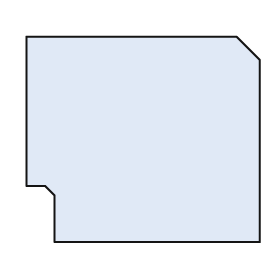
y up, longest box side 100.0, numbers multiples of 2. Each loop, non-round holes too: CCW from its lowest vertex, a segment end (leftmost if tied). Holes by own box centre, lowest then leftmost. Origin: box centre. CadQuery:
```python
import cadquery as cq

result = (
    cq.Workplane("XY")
    .moveTo(-38.0, -44.0)
    .lineTo(50.0, -44.0)
    .lineTo(50.0, 34.0)
    .lineTo(40.0, 44.0)
    .lineTo(-50.0, 44.0)
    .lineTo(-50.0, -20.0)
    .lineTo(-42.0, -20.0)
    .lineTo(-38.0, -24.0)
    .close()
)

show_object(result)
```